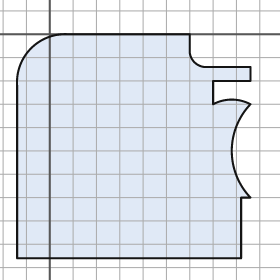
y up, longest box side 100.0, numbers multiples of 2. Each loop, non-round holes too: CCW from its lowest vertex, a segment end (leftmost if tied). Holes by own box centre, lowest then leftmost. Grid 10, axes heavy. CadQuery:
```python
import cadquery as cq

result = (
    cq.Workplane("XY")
    .moveTo(-14.0, -96.0)
    .lineTo(82.0, -96.0)
    .lineTo(82.0, -70.0)
    .lineTo(86.0, -70.0)
    .threePointArc((78.0, -50.0), (86.0, -30.0))
    .threePointArc((78.0, -28.0), (70.0, -30.0))
    .lineTo(70.0, -20.0)
    .lineTo(86.0, -20.0)
    .lineTo(86.0, -14.0)
    .lineTo(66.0, -14.0)
    .threePointArc((62.0, -12.0), (60.0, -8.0))
    .lineTo(60.0, 0.0)
    .lineTo(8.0, 0.0)
    .threePointArc((-8.0, -6.0), (-14.0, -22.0))
    .close()
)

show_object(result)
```